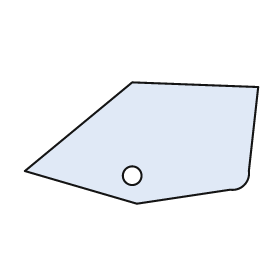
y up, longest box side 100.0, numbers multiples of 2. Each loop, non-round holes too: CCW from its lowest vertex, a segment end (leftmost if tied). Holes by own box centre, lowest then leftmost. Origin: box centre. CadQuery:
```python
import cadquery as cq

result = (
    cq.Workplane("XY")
    .moveTo(-2.0, -26.0)
    .lineTo(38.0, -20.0)
    .threePointArc((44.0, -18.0), (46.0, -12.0))
    .lineTo(50.0, 24.0)
    .lineTo(-4.0, 26.0)
    .lineTo(-50.0, -12.0)
    .close()
    .moveTo(-4.0, -14.0)
    .circle(4.0)
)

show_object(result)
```